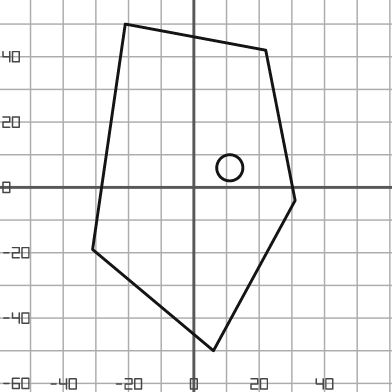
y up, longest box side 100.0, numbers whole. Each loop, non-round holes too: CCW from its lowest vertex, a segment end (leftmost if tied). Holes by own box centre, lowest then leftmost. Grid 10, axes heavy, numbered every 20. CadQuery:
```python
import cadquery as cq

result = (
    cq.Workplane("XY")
    .moveTo(6.0, -50.0)
    .lineTo(31.0, -4.0)
    .lineTo(22.0, 42.0)
    .lineTo(-21.0, 50.0)
    .lineTo(-31.0, -19.0)
    .close()
    .moveTo(11.0, 6.0)
    .circle(4.0)
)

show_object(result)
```